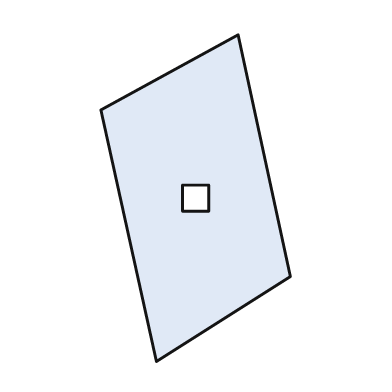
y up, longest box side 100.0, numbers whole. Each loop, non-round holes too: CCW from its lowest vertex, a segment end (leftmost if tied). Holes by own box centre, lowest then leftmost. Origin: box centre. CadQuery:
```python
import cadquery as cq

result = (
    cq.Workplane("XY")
    .moveTo(-12.0, -50.0)
    .lineTo(29.0, -24.0)
    .lineTo(13.0, 50.0)
    .lineTo(-29.0, 27.0)
    .close()
    .moveTo(-4.0, -4.0)
    .lineTo(4.0, -4.0)
    .lineTo(4.0, 4.0)
    .lineTo(-4.0, 4.0)
    .close()
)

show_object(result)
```